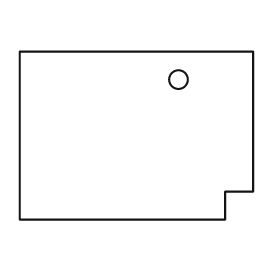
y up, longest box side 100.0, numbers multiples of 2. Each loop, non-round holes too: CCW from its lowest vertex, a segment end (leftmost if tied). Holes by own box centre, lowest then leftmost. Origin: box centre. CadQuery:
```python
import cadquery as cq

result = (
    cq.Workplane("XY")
    .moveTo(-50.0, -36.0)
    .lineTo(38.0, -36.0)
    .lineTo(38.0, -24.0)
    .lineTo(50.0, -24.0)
    .lineTo(50.0, 36.0)
    .lineTo(-50.0, 36.0)
    .close()
    .moveTo(18.0, 24.0)
    .circle(4.0)
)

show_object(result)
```